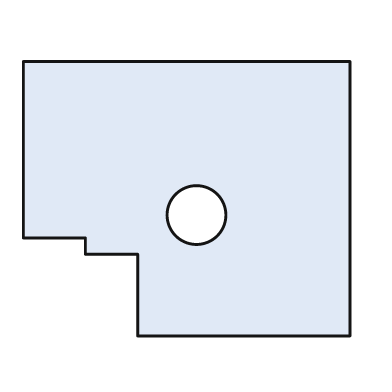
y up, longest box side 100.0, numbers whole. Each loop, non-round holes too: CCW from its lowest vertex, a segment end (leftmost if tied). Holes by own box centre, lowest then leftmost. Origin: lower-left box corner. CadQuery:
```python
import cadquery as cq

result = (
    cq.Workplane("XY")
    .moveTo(35.0, 0.0)
    .lineTo(100.0, 0.0)
    .lineTo(100.0, 84.0)
    .lineTo(0.0, 84.0)
    .lineTo(0.0, 30.0)
    .lineTo(19.0, 30.0)
    .lineTo(19.0, 25.0)
    .lineTo(35.0, 25.0)
    .close()
    .moveTo(53.0, 37.0)
    .circle(9.0)
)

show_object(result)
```